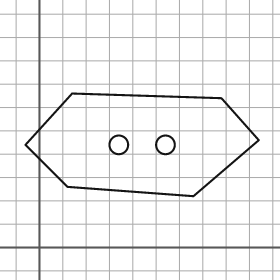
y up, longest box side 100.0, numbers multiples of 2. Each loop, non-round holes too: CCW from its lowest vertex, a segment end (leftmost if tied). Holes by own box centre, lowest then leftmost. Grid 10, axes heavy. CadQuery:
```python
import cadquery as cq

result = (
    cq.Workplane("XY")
    .moveTo(66.0, 22.0)
    .lineTo(94.0, 46.0)
    .lineTo(78.0, 64.0)
    .lineTo(14.0, 66.0)
    .lineTo(-6.0, 44.0)
    .lineTo(12.0, 26.0)
    .close()
    .moveTo(34.0, 44.0)
    .circle(4.0)
    .moveTo(54.0, 44.0)
    .circle(4.0)
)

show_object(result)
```